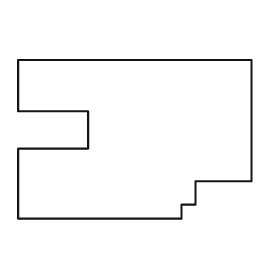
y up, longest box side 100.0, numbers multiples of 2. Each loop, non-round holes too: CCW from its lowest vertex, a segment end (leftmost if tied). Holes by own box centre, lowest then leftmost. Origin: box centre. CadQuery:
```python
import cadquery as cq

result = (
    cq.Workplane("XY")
    .moveTo(-50.0, -34.0)
    .lineTo(20.0, -34.0)
    .lineTo(20.0, -28.0)
    .lineTo(26.0, -28.0)
    .lineTo(26.0, -18.0)
    .lineTo(50.0, -18.0)
    .lineTo(50.0, 34.0)
    .lineTo(-50.0, 34.0)
    .lineTo(-50.0, 12.0)
    .lineTo(-20.0, 12.0)
    .lineTo(-20.0, -4.0)
    .lineTo(-50.0, -4.0)
    .close()
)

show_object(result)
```